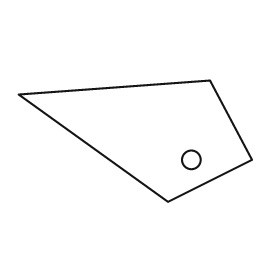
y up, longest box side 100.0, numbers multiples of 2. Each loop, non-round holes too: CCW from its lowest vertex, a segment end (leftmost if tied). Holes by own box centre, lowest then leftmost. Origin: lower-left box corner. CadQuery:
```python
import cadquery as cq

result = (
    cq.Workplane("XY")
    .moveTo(64.0, 0.0)
    .lineTo(100.0, 18.0)
    .lineTo(82.0, 52.0)
    .lineTo(0.0, 46.0)
    .close()
    .moveTo(74.0, 18.0)
    .circle(4.0)
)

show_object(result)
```